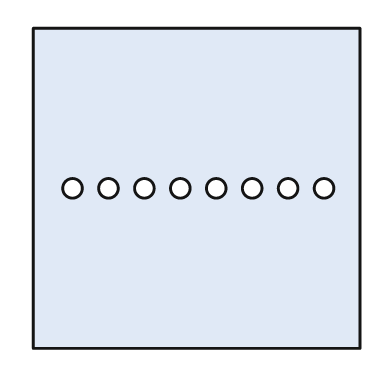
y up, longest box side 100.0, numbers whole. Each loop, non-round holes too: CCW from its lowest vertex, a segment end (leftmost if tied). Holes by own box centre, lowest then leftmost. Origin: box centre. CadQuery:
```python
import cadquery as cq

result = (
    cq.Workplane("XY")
    .moveTo(-50.0, -49.0)
    .lineTo(50.0, -49.0)
    .lineTo(50.0, 49.0)
    .lineTo(-50.0, 49.0)
    .close()
    .moveTo(-38.0, 0.0)
    .circle(3.0)
    .moveTo(-27.0, 0.0)
    .circle(3.0)
    .moveTo(-16.0, 0.0)
    .circle(3.0)
    .moveTo(-5.0, 0.0)
    .circle(3.0)
    .moveTo(6.0, 0.0)
    .circle(3.0)
    .moveTo(17.0, 0.0)
    .circle(3.0)
    .moveTo(28.0, 0.0)
    .circle(3.0)
    .moveTo(39.0, 0.0)
    .circle(3.0)
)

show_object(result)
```